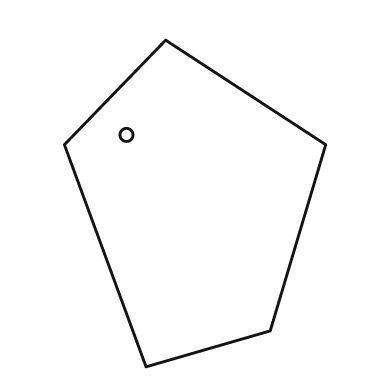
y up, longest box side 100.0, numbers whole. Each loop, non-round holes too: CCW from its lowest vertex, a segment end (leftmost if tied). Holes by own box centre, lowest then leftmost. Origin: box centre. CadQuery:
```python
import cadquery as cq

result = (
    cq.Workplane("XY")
    .moveTo(-15.0, -50.0)
    .lineTo(23.0, -39.0)
    .lineTo(40.0, 18.0)
    .lineTo(-9.0, 50.0)
    .lineTo(-40.0, 18.0)
    .close()
    .moveTo(-21.0, 21.0)
    .circle(2.0)
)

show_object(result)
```